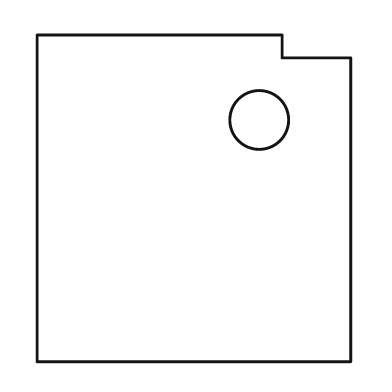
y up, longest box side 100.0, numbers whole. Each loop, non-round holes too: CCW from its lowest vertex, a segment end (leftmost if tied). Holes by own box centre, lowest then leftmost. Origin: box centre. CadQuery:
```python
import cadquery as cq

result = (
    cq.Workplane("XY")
    .moveTo(-48.0, -50.0)
    .lineTo(48.0, -50.0)
    .lineTo(48.0, 43.0)
    .lineTo(27.0, 43.0)
    .lineTo(27.0, 50.0)
    .lineTo(-48.0, 50.0)
    .close()
    .moveTo(20.0, 24.0)
    .circle(9.0)
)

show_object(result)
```